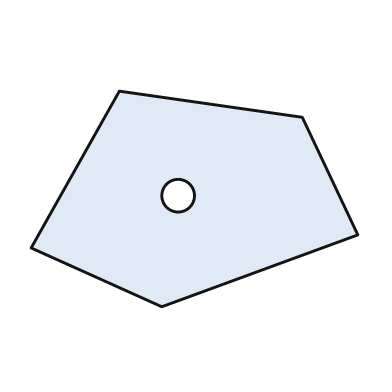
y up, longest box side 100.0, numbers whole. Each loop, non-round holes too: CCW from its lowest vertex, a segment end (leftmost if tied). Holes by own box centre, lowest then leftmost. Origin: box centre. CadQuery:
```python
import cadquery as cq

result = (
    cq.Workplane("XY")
    .moveTo(-10.0, -33.0)
    .lineTo(50.0, -11.0)
    .lineTo(33.0, 25.0)
    .lineTo(-23.0, 33.0)
    .lineTo(-50.0, -15.0)
    .close()
    .moveTo(-5.0, 1.0)
    .circle(5.0)
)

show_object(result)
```